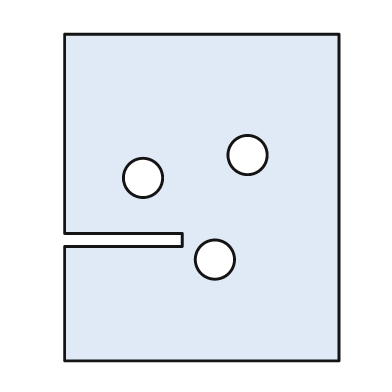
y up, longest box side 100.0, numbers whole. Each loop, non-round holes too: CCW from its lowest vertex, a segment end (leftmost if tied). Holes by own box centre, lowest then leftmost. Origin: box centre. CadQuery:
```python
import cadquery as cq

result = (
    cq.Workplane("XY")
    .moveTo(-42.0, -50.0)
    .lineTo(42.0, -50.0)
    .lineTo(42.0, 50.0)
    .lineTo(-42.0, 50.0)
    .lineTo(-42.0, -11.0)
    .lineTo(-6.0, -11.0)
    .lineTo(-6.0, -15.0)
    .lineTo(-42.0, -15.0)
    .close()
    .moveTo(4.0, -19.0)
    .circle(6.0)
    .moveTo(-18.0, 6.0)
    .circle(6.0)
    .moveTo(14.0, 13.0)
    .circle(6.0)
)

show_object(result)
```